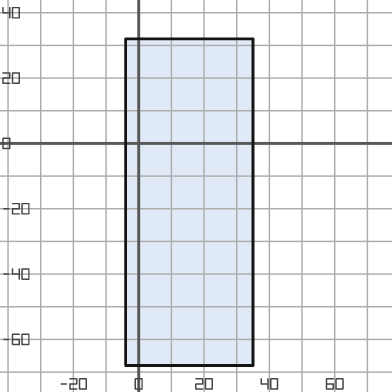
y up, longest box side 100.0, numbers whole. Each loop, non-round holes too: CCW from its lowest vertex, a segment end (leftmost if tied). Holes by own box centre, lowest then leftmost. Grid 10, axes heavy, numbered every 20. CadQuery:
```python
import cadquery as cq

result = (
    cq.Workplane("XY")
    .moveTo(-4.0, -68.0)
    .lineTo(35.0, -68.0)
    .lineTo(35.0, 32.0)
    .lineTo(-4.0, 32.0)
    .close()
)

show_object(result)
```